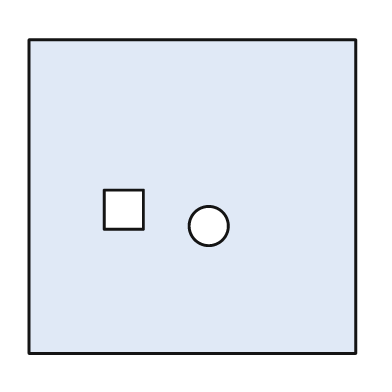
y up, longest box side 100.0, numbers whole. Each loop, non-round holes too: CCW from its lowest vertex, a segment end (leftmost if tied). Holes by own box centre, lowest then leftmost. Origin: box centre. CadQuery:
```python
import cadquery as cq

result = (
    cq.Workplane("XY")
    .moveTo(-50.0, -48.0)
    .lineTo(50.0, -48.0)
    .lineTo(50.0, 48.0)
    .lineTo(-50.0, 48.0)
    .close()
    .moveTo(5.0, -9.0)
    .circle(6.0)
    .moveTo(-27.0, -10.0)
    .lineTo(-15.0, -10.0)
    .lineTo(-15.0, 2.0)
    .lineTo(-27.0, 2.0)
    .close()
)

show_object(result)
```